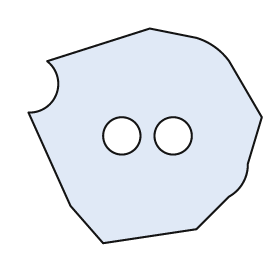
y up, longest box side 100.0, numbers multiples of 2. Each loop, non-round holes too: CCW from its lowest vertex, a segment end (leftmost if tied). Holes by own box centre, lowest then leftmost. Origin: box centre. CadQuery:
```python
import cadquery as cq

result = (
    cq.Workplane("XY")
    .moveTo(-18.0, -46.0)
    .lineTo(22.0, -40.0)
    .lineTo(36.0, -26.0)
    .threePointArc((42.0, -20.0), (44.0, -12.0))
    .lineTo(50.0, 8.0)
    .lineTo(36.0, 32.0)
    .threePointArc((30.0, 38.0), (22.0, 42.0))
    .lineTo(2.0, 46.0)
    .lineTo(-42.0, 32.0)
    .threePointArc((-38.0, 18.0), (-50.0, 10.0))
    .lineTo(-32.0, -30.0)
    .close()
    .moveTo(-10.0, 0.0)
    .circle(8.0)
    .moveTo(12.0, 0.0)
    .circle(8.0)
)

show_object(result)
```